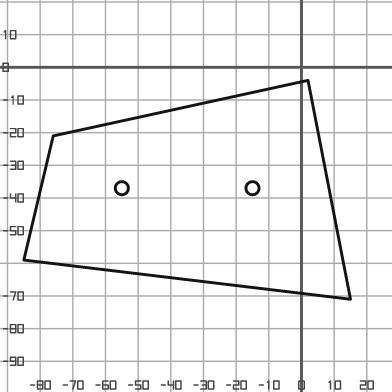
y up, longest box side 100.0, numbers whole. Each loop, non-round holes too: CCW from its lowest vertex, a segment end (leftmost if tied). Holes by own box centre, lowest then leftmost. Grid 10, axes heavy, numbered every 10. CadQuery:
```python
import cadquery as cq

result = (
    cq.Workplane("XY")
    .moveTo(15.0, -71.0)
    .lineTo(2.0, -4.0)
    .lineTo(-76.0, -21.0)
    .lineTo(-85.0, -59.0)
    .close()
    .moveTo(-55.0, -37.0)
    .circle(2.0)
    .moveTo(-15.0, -37.0)
    .circle(2.0)
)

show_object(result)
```